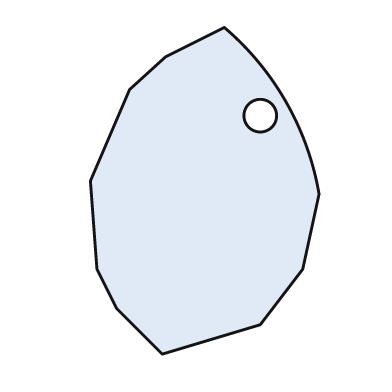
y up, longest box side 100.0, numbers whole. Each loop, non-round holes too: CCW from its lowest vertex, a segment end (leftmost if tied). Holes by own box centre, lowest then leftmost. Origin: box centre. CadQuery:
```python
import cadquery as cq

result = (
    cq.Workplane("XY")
    .moveTo(-13.0, -50.0)
    .lineTo(17.0, -41.0)
    .lineTo(30.0, -24.0)
    .lineTo(35.0, -1.0)
    .threePointArc((25.0, 27.0), (6.0, 50.0))
    .lineTo(-12.0, 41.0)
    .lineTo(-23.0, 31.0)
    .lineTo(-35.0, 3.0)
    .lineTo(-33.0, -24.0)
    .lineTo(-27.0, -36.0)
    .close()
    .moveTo(17.0, 23.0)
    .circle(5.0)
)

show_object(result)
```